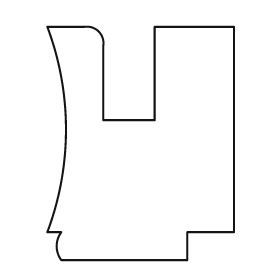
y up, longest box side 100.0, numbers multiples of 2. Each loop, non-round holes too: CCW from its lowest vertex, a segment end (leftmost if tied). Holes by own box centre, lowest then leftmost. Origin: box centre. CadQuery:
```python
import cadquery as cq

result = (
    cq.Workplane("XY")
    .moveTo(-34.0, -50.0)
    .lineTo(20.0, -50.0)
    .lineTo(20.0, -38.0)
    .lineTo(40.0, -38.0)
    .lineTo(40.0, 50.0)
    .lineTo(6.0, 50.0)
    .lineTo(6.0, 10.0)
    .lineTo(-16.0, 10.0)
    .lineTo(-16.0, 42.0)
    .threePointArc((-18.0, 48.0), (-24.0, 50.0))
    .lineTo(-40.0, 50.0)
    .threePointArc((-32.0, 6.0), (-40.0, -38.0))
    .lineTo(-34.0, -38.0)
    .threePointArc((-36.0, -44.0), (-34.0, -50.0))
    .close()
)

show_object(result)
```